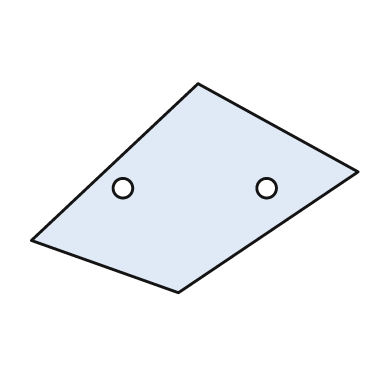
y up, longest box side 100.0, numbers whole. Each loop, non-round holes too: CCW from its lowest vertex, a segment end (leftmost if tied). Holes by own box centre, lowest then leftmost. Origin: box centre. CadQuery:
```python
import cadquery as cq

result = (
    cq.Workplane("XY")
    .moveTo(-5.0, -32.0)
    .lineTo(50.0, 5.0)
    .lineTo(1.0, 32.0)
    .lineTo(-50.0, -16.0)
    .close()
    .moveTo(-22.0, 0.0)
    .circle(3.0)
    .moveTo(22.0, 0.0)
    .circle(3.0)
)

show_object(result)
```